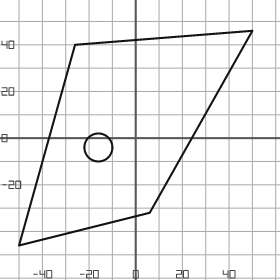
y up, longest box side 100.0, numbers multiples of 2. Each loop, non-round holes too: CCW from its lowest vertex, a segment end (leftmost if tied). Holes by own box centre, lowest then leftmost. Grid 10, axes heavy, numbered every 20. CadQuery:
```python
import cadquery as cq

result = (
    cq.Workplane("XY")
    .moveTo(-50.0, -46.0)
    .lineTo(6.0, -32.0)
    .lineTo(50.0, 46.0)
    .lineTo(-26.0, 40.0)
    .close()
    .moveTo(-16.0, -4.0)
    .circle(6.0)
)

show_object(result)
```